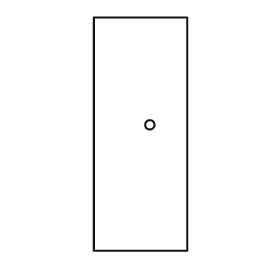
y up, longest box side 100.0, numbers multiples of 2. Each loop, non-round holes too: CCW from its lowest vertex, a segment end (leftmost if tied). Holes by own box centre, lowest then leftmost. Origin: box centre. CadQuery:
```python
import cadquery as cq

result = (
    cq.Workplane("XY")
    .moveTo(-20.0, -50.0)
    .lineTo(20.0, -50.0)
    .lineTo(20.0, 50.0)
    .lineTo(-20.0, 50.0)
    .close()
    .moveTo(4.0, 4.0)
    .circle(2.0)
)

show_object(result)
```